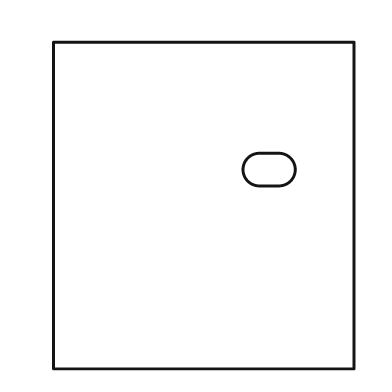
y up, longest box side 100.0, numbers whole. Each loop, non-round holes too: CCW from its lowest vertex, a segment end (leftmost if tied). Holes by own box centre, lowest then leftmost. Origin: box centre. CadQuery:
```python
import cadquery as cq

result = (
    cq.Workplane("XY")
    .moveTo(-46.0, -50.0)
    .lineTo(46.0, -50.0)
    .lineTo(46.0, 50.0)
    .lineTo(-46.0, 50.0)
    .close()
    .moveTo(17.0, 6.0)
    .lineTo(23.0, 6.0)
    .threePointArc((28.0, 11.0), (23.0, 16.0))
    .lineTo(17.0, 16.0)
    .threePointArc((12.0, 11.0), (17.0, 6.0))
    .close()
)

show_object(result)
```